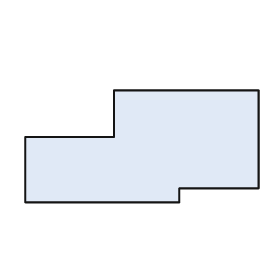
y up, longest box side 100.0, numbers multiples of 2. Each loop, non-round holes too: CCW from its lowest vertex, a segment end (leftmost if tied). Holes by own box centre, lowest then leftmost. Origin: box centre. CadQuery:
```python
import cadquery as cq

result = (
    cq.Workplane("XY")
    .moveTo(-50.0, -24.0)
    .lineTo(16.0, -24.0)
    .lineTo(16.0, -18.0)
    .lineTo(50.0, -18.0)
    .lineTo(50.0, 24.0)
    .lineTo(-12.0, 24.0)
    .lineTo(-12.0, 4.0)
    .lineTo(-50.0, 4.0)
    .close()
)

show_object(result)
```